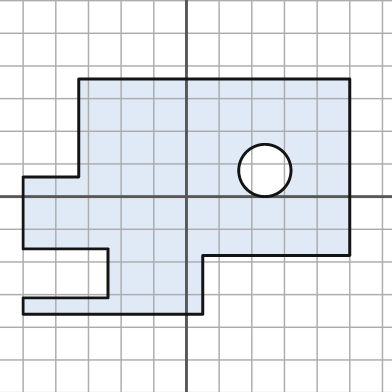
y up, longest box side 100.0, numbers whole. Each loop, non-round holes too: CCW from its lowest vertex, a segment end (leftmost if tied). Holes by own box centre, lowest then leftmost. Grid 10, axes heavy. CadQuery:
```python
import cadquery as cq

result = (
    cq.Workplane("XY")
    .moveTo(-50.0, -36.0)
    .lineTo(5.0, -36.0)
    .lineTo(5.0, -18.0)
    .lineTo(50.0, -18.0)
    .lineTo(50.0, 36.0)
    .lineTo(-33.0, 36.0)
    .lineTo(-33.0, 6.0)
    .lineTo(-50.0, 6.0)
    .lineTo(-50.0, -16.0)
    .lineTo(-24.0, -16.0)
    .lineTo(-24.0, -31.0)
    .lineTo(-50.0, -31.0)
    .close()
    .moveTo(24.0, 8.0)
    .circle(8.0)
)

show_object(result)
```